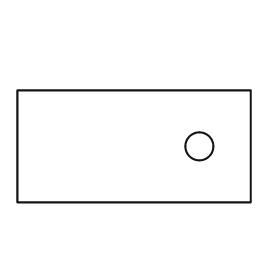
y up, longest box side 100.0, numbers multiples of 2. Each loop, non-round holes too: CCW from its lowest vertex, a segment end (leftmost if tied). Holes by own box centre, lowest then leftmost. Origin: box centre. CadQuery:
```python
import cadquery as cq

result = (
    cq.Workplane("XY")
    .moveTo(-50.0, -24.0)
    .lineTo(50.0, -24.0)
    .lineTo(50.0, 24.0)
    .lineTo(-50.0, 24.0)
    .close()
    .moveTo(28.0, 0.0)
    .circle(6.0)
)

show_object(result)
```